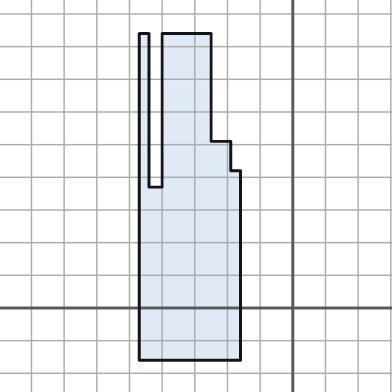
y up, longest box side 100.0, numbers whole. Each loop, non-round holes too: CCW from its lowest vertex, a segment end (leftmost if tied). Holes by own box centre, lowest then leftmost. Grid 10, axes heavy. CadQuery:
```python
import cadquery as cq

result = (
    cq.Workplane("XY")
    .moveTo(-47.0, -16.0)
    .lineTo(-16.0, -16.0)
    .lineTo(-16.0, 42.0)
    .lineTo(-19.0, 42.0)
    .lineTo(-19.0, 51.0)
    .lineTo(-25.0, 51.0)
    .lineTo(-25.0, 84.0)
    .lineTo(-40.0, 84.0)
    .lineTo(-40.0, 37.0)
    .lineTo(-44.0, 37.0)
    .lineTo(-44.0, 84.0)
    .lineTo(-47.0, 84.0)
    .close()
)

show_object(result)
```